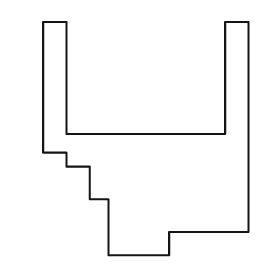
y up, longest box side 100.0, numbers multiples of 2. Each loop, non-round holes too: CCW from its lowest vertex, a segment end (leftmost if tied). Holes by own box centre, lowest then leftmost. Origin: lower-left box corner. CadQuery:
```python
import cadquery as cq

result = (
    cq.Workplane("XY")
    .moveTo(28.0, 0.0)
    .lineTo(54.0, 0.0)
    .lineTo(54.0, 10.0)
    .lineTo(88.0, 10.0)
    .lineTo(88.0, 100.0)
    .lineTo(78.0, 100.0)
    .lineTo(78.0, 52.0)
    .lineTo(10.0, 52.0)
    .lineTo(10.0, 100.0)
    .lineTo(0.0, 100.0)
    .lineTo(0.0, 44.0)
    .lineTo(10.0, 44.0)
    .lineTo(10.0, 38.0)
    .lineTo(20.0, 38.0)
    .lineTo(20.0, 24.0)
    .lineTo(28.0, 24.0)
    .close()
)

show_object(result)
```